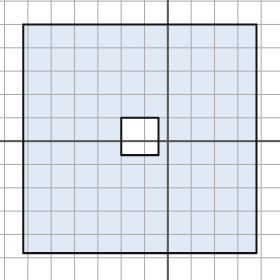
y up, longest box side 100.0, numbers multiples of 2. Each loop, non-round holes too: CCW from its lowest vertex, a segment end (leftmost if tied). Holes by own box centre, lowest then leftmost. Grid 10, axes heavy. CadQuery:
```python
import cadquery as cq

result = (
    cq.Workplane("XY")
    .moveTo(-62.0, -48.0)
    .lineTo(38.0, -48.0)
    .lineTo(38.0, 50.0)
    .lineTo(-62.0, 50.0)
    .close()
    .moveTo(-20.0, -6.0)
    .lineTo(-4.0, -6.0)
    .lineTo(-4.0, 10.0)
    .lineTo(-20.0, 10.0)
    .close()
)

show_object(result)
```